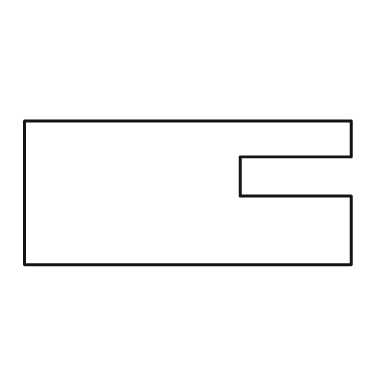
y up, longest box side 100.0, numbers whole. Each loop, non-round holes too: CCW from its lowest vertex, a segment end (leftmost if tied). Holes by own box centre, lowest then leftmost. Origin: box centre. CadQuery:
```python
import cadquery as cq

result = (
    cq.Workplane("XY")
    .moveTo(-50.0, -22.0)
    .lineTo(50.0, -22.0)
    .lineTo(50.0, -1.0)
    .lineTo(16.0, -1.0)
    .lineTo(16.0, 11.0)
    .lineTo(50.0, 11.0)
    .lineTo(50.0, 22.0)
    .lineTo(-50.0, 22.0)
    .close()
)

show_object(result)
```